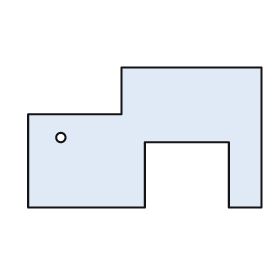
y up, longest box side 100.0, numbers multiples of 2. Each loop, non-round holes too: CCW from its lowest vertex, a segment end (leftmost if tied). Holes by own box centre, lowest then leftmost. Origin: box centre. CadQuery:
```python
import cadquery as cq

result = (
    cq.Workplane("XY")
    .moveTo(-50.0, -30.0)
    .lineTo(0.0, -30.0)
    .lineTo(0.0, -2.0)
    .lineTo(36.0, -2.0)
    .lineTo(36.0, -30.0)
    .lineTo(50.0, -30.0)
    .lineTo(50.0, 30.0)
    .lineTo(-10.0, 30.0)
    .lineTo(-10.0, 10.0)
    .lineTo(-50.0, 10.0)
    .close()
    .moveTo(-36.0, 0.0)
    .circle(2.0)
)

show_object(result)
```